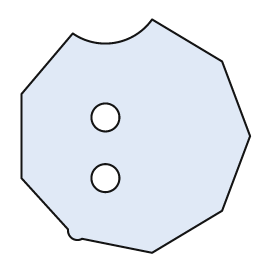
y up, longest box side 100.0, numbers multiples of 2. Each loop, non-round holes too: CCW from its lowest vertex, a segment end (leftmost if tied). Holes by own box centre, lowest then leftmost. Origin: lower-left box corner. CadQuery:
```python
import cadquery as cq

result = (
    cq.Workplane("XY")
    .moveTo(56.0, 0.0)
    .lineTo(86.0, 18.0)
    .lineTo(98.0, 50.0)
    .lineTo(86.0, 82.0)
    .lineTo(56.0, 100.0)
    .threePointArc((40.0, 90.0), (22.0, 94.0))
    .lineTo(0.0, 68.0)
    .lineTo(0.0, 32.0)
    .lineTo(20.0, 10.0)
    .threePointArc((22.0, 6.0), (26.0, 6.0))
    .close()
    .moveTo(36.0, 32.0)
    .circle(6.0)
    .moveTo(36.0, 58.0)
    .circle(6.0)
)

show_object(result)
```